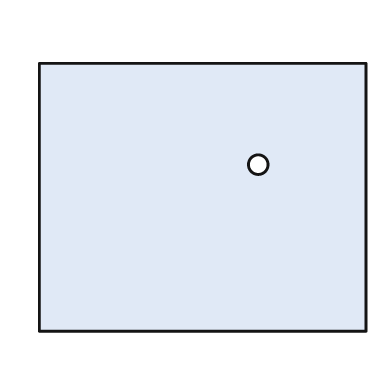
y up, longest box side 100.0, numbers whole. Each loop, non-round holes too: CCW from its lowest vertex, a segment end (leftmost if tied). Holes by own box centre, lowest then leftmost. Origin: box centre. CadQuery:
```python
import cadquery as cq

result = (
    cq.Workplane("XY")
    .moveTo(-50.0, -41.0)
    .lineTo(50.0, -41.0)
    .lineTo(50.0, 41.0)
    .lineTo(-50.0, 41.0)
    .close()
    .moveTo(17.0, 10.0)
    .circle(3.0)
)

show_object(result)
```